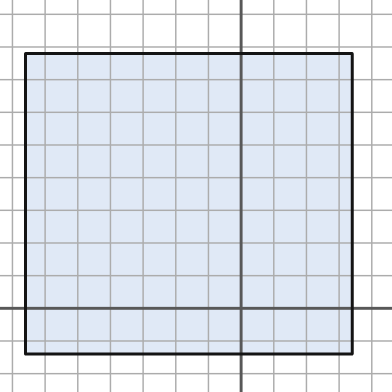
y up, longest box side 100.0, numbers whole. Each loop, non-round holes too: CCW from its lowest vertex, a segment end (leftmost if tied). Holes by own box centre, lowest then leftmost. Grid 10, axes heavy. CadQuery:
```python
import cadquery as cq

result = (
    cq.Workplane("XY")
    .moveTo(-66.0, -14.0)
    .lineTo(34.0, -14.0)
    .lineTo(34.0, 78.0)
    .lineTo(-66.0, 78.0)
    .close()
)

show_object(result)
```